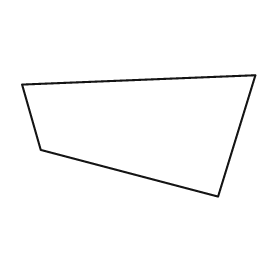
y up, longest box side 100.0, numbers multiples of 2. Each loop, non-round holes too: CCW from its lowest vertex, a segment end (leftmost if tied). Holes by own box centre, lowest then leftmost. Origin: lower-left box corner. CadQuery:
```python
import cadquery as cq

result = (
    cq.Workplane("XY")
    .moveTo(84.0, 0.0)
    .lineTo(100.0, 52.0)
    .lineTo(0.0, 48.0)
    .lineTo(8.0, 20.0)
    .close()
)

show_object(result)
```